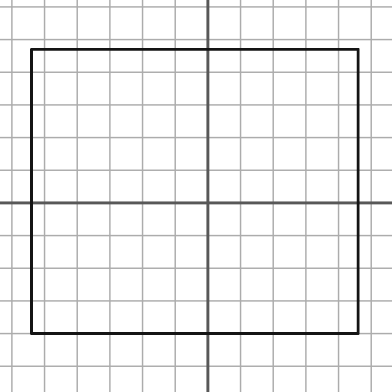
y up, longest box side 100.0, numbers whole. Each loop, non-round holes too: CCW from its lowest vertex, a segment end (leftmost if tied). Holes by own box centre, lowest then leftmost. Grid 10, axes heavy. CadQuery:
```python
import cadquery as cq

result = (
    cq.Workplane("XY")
    .moveTo(-54.0, -40.0)
    .lineTo(46.0, -40.0)
    .lineTo(46.0, 47.0)
    .lineTo(-54.0, 47.0)
    .close()
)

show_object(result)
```